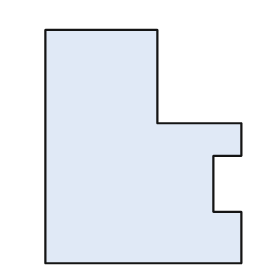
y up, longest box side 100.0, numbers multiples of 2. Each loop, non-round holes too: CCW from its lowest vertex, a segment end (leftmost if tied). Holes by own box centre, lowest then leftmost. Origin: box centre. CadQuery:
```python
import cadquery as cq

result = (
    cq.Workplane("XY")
    .moveTo(-42.0, -50.0)
    .lineTo(42.0, -50.0)
    .lineTo(42.0, -28.0)
    .lineTo(30.0, -28.0)
    .lineTo(30.0, -4.0)
    .lineTo(42.0, -4.0)
    .lineTo(42.0, 10.0)
    .lineTo(6.0, 10.0)
    .lineTo(6.0, 50.0)
    .lineTo(-42.0, 50.0)
    .close()
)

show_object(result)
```